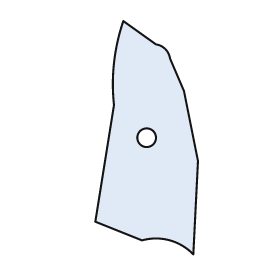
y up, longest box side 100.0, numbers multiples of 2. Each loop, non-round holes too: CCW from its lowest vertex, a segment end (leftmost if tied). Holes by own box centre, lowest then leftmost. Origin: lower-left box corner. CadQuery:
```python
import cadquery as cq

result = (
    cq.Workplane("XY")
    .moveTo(42.0, 0.0)
    .lineTo(44.0, 40.0)
    .lineTo(38.0, 70.0)
    .lineTo(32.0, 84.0)
    .threePointArc((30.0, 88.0), (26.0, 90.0))
    .lineTo(12.0, 100.0)
    .threePointArc((8.0, 82.0), (8.0, 64.0))
    .lineTo(0.0, 14.0)
    .lineTo(20.0, 6.0)
    .threePointArc((32.0, 6.0), (42.0, 0.0))
    .close()
    .moveTo(22.0, 50.0)
    .circle(4.0)
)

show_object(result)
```